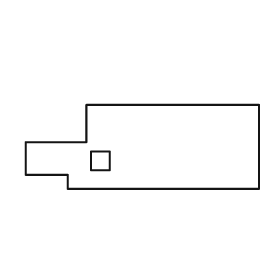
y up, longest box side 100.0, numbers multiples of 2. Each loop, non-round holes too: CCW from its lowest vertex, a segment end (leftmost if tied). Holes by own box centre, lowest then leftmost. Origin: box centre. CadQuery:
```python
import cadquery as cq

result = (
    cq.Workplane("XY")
    .moveTo(-32.0, -18.0)
    .lineTo(50.0, -18.0)
    .lineTo(50.0, 18.0)
    .lineTo(-24.0, 18.0)
    .lineTo(-24.0, 2.0)
    .lineTo(-50.0, 2.0)
    .lineTo(-50.0, -12.0)
    .lineTo(-32.0, -12.0)
    .close()
    .moveTo(-22.0, -10.0)
    .lineTo(-14.0, -10.0)
    .lineTo(-14.0, -2.0)
    .lineTo(-22.0, -2.0)
    .close()
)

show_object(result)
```